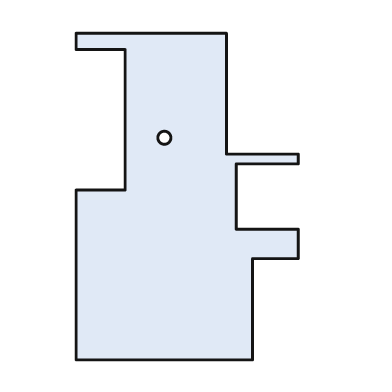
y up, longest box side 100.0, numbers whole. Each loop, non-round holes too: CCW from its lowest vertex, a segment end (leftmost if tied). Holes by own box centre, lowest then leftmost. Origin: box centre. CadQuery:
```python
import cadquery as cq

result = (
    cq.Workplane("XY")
    .moveTo(-34.0, -50.0)
    .lineTo(20.0, -50.0)
    .lineTo(20.0, -19.0)
    .lineTo(34.0, -19.0)
    .lineTo(34.0, -10.0)
    .lineTo(15.0, -10.0)
    .lineTo(15.0, 10.0)
    .lineTo(34.0, 10.0)
    .lineTo(34.0, 13.0)
    .lineTo(12.0, 13.0)
    .lineTo(12.0, 50.0)
    .lineTo(-34.0, 50.0)
    .lineTo(-34.0, 45.0)
    .lineTo(-19.0, 45.0)
    .lineTo(-19.0, 2.0)
    .lineTo(-34.0, 2.0)
    .close()
    .moveTo(-7.0, 18.0)
    .circle(2.0)
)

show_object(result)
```